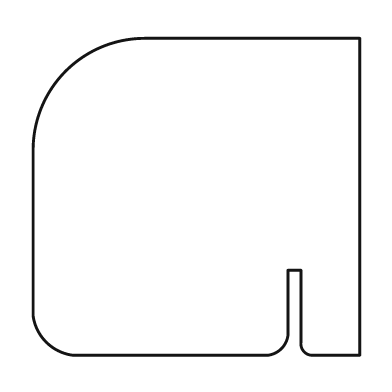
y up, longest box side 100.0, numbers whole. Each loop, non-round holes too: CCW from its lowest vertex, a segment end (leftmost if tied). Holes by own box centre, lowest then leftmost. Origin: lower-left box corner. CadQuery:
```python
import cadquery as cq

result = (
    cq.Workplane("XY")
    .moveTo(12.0, 0.0)
    .lineTo(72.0, 0.0)
    .threePointArc((76.0, 2.0), (78.0, 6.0))
    .lineTo(78.0, 26.0)
    .lineTo(82.0, 26.0)
    .lineTo(82.0, 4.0)
    .threePointArc((83.0, 1.0), (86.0, 0.0))
    .lineTo(100.0, 0.0)
    .lineTo(100.0, 97.0)
    .lineTo(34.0, 97.0)
    .threePointArc((10.0, 87.0), (0.0, 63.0))
    .lineTo(0.0, 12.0)
    .threePointArc((4.0, 4.0), (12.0, 0.0))
    .close()
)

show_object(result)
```